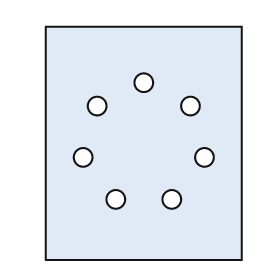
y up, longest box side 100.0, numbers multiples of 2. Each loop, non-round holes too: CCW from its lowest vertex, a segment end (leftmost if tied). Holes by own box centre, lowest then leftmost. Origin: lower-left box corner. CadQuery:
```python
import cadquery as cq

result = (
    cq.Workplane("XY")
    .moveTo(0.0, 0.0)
    .lineTo(84.0, 0.0)
    .lineTo(84.0, 100.0)
    .lineTo(0.0, 100.0)
    .close()
    .moveTo(30.0, 26.0)
    .circle(4.0)
    .moveTo(54.0, 26.0)
    .circle(4.0)
    .moveTo(16.0, 44.0)
    .circle(4.0)
    .moveTo(68.0, 44.0)
    .circle(4.0)
    .moveTo(22.0, 66.0)
    .circle(4.0)
    .moveTo(62.0, 66.0)
    .circle(4.0)
    .moveTo(42.0, 76.0)
    .circle(4.0)
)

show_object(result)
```